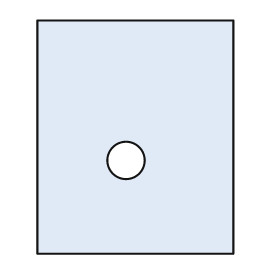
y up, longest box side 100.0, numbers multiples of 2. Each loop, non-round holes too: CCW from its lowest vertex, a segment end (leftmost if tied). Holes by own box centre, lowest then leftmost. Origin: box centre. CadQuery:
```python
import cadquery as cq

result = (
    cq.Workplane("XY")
    .moveTo(-42.0, -50.0)
    .lineTo(42.0, -50.0)
    .lineTo(42.0, 50.0)
    .lineTo(-42.0, 50.0)
    .close()
    .moveTo(-4.0, -10.0)
    .circle(8.0)
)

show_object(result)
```